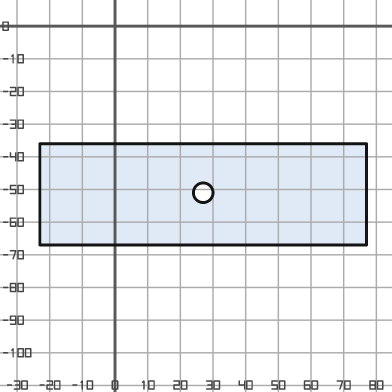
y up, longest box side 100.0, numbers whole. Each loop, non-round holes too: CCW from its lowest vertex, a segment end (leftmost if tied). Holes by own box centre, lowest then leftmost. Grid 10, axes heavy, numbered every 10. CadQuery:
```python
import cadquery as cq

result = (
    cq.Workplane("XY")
    .moveTo(-23.0, -67.0)
    .lineTo(77.0, -67.0)
    .lineTo(77.0, -36.0)
    .lineTo(-23.0, -36.0)
    .close()
    .moveTo(27.0, -51.0)
    .circle(3.0)
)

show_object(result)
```